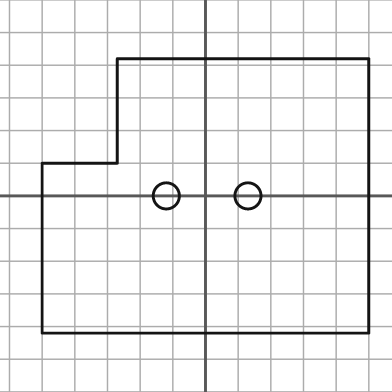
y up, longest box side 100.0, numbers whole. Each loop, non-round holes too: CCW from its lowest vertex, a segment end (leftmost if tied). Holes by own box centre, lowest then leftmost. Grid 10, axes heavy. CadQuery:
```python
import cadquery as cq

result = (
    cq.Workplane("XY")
    .moveTo(-50.0, -42.0)
    .lineTo(50.0, -42.0)
    .lineTo(50.0, 42.0)
    .lineTo(-27.0, 42.0)
    .lineTo(-27.0, 10.0)
    .lineTo(-50.0, 10.0)
    .close()
    .moveTo(-12.0, 0.0)
    .circle(4.0)
    .moveTo(13.0, 0.0)
    .circle(4.0)
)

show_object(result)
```